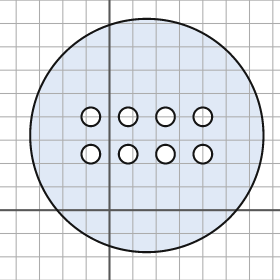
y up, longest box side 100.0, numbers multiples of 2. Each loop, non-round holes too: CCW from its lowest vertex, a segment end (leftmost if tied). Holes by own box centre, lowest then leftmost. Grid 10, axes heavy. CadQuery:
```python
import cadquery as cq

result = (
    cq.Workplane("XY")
    .moveTo(16.0, 32.0)
    .circle(50.0)
    .moveTo(-8.0, 24.0)
    .circle(4.0)
    .moveTo(8.0, 24.0)
    .circle(4.0)
    .moveTo(24.0, 24.0)
    .circle(4.0)
    .moveTo(40.0, 24.0)
    .circle(4.0)
    .moveTo(-8.0, 40.0)
    .circle(4.0)
    .moveTo(8.0, 40.0)
    .circle(4.0)
    .moveTo(24.0, 40.0)
    .circle(4.0)
    .moveTo(40.0, 40.0)
    .circle(4.0)
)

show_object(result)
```